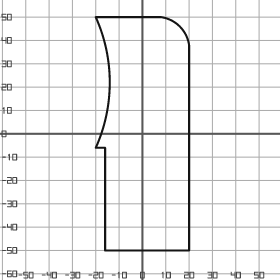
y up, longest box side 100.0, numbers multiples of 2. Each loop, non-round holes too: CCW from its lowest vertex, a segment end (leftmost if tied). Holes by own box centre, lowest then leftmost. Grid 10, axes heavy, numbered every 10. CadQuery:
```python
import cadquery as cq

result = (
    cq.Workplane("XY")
    .moveTo(-16.0, -50.0)
    .lineTo(20.0, -50.0)
    .lineTo(20.0, 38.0)
    .threePointArc((16.0, 46.0), (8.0, 50.0))
    .lineTo(-20.0, 50.0)
    .threePointArc((-14.0, 22.0), (-20.0, -6.0))
    .lineTo(-16.0, -6.0)
    .close()
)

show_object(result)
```